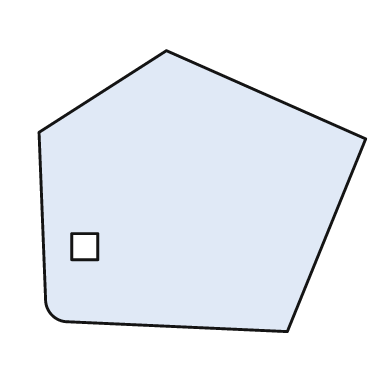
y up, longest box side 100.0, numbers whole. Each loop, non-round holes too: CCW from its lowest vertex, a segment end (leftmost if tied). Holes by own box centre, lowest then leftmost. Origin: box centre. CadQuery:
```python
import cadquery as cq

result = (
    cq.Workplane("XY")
    .moveTo(26.0, -43.0)
    .lineTo(50.0, 16.0)
    .lineTo(-11.0, 43.0)
    .lineTo(-50.0, 18.0)
    .lineTo(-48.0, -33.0)
    .threePointArc((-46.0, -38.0), (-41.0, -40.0))
    .close()
    .moveTo(-40.0, -21.0)
    .lineTo(-32.0, -21.0)
    .lineTo(-32.0, -13.0)
    .lineTo(-40.0, -13.0)
    .close()
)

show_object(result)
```